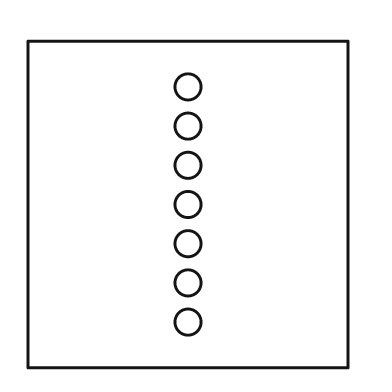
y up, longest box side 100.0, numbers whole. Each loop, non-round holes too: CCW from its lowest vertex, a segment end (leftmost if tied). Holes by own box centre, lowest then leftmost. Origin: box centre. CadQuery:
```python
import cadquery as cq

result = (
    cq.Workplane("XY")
    .moveTo(-49.0, -50.0)
    .lineTo(49.0, -50.0)
    .lineTo(49.0, 50.0)
    .lineTo(-49.0, 50.0)
    .close()
    .moveTo(0.0, -36.0)
    .circle(4.0)
    .moveTo(0.0, -24.0)
    .circle(4.0)
    .moveTo(0.0, -12.0)
    .circle(4.0)
    .moveTo(0.0, 0.0)
    .circle(4.0)
    .moveTo(0.0, 12.0)
    .circle(4.0)
    .moveTo(0.0, 24.0)
    .circle(4.0)
    .moveTo(0.0, 36.0)
    .circle(4.0)
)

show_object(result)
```